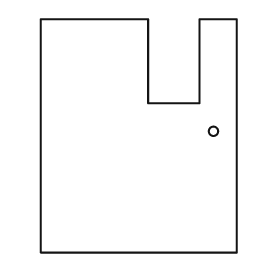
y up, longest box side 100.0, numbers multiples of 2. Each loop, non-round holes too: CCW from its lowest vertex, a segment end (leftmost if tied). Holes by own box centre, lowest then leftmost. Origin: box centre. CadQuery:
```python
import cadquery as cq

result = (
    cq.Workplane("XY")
    .moveTo(-42.0, -50.0)
    .lineTo(42.0, -50.0)
    .lineTo(42.0, 50.0)
    .lineTo(26.0, 50.0)
    .lineTo(26.0, 14.0)
    .lineTo(4.0, 14.0)
    .lineTo(4.0, 50.0)
    .lineTo(-42.0, 50.0)
    .close()
    .moveTo(32.0, 2.0)
    .circle(2.0)
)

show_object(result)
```